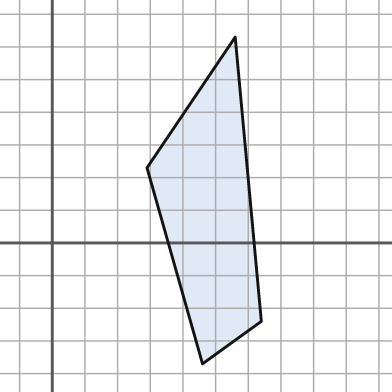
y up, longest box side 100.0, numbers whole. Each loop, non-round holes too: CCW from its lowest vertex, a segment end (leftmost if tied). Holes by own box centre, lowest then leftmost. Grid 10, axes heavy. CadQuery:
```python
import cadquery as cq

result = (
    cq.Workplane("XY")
    .moveTo(46.0, -37.0)
    .lineTo(64.0, -24.0)
    .lineTo(56.0, 63.0)
    .lineTo(29.0, 23.0)
    .close()
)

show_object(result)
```